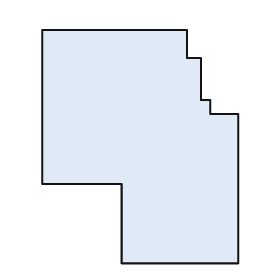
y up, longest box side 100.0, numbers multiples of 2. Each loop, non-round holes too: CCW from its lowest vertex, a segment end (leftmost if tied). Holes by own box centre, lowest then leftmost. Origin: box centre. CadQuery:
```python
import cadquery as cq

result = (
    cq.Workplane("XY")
    .moveTo(-8.0, -50.0)
    .lineTo(42.0, -50.0)
    .lineTo(42.0, 14.0)
    .lineTo(30.0, 14.0)
    .lineTo(30.0, 20.0)
    .lineTo(26.0, 20.0)
    .lineTo(26.0, 38.0)
    .lineTo(20.0, 38.0)
    .lineTo(20.0, 50.0)
    .lineTo(-42.0, 50.0)
    .lineTo(-42.0, -16.0)
    .lineTo(-8.0, -16.0)
    .close()
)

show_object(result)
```